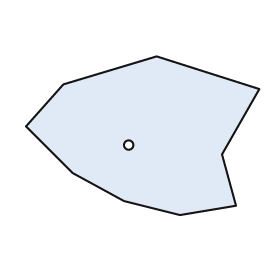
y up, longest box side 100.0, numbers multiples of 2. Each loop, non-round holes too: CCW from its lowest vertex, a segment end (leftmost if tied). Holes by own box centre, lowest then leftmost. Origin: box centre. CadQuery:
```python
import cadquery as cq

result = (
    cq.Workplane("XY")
    .moveTo(16.0, -34.0)
    .lineTo(40.0, -30.0)
    .lineTo(34.0, -8.0)
    .lineTo(50.0, 20.0)
    .lineTo(6.0, 34.0)
    .lineTo(-34.0, 22.0)
    .lineTo(-50.0, 4.0)
    .lineTo(-30.0, -16.0)
    .lineTo(-8.0, -28.0)
    .close()
    .moveTo(-6.0, -4.0)
    .circle(2.0)
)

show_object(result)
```